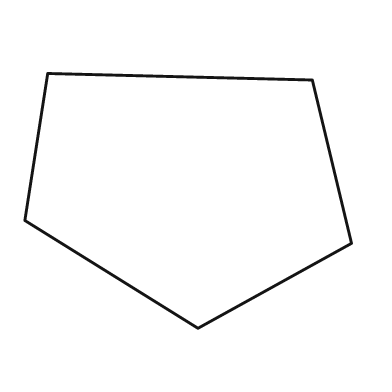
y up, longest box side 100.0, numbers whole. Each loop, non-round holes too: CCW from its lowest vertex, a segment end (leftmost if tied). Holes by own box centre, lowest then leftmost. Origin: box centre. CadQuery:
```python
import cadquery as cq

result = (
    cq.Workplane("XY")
    .moveTo(3.0, -39.0)
    .lineTo(50.0, -13.0)
    .lineTo(38.0, 37.0)
    .lineTo(-43.0, 39.0)
    .lineTo(-50.0, -6.0)
    .close()
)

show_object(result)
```